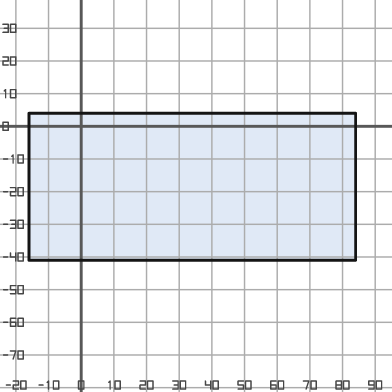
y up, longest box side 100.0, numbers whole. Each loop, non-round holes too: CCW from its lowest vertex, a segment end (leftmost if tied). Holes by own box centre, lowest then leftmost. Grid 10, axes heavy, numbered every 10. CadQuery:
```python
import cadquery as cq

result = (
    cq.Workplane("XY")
    .moveTo(-16.0, -41.0)
    .lineTo(84.0, -41.0)
    .lineTo(84.0, 4.0)
    .lineTo(-16.0, 4.0)
    .close()
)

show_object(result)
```